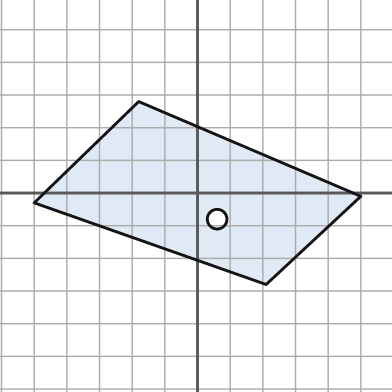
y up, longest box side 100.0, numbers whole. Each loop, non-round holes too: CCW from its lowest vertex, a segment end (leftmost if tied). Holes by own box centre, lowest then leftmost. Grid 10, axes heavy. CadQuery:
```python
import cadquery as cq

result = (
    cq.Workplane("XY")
    .moveTo(21.0, -28.0)
    .lineTo(50.0, -1.0)
    .lineTo(-18.0, 28.0)
    .lineTo(-50.0, -3.0)
    .close()
    .moveTo(6.0, -8.0)
    .circle(3.0)
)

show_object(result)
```